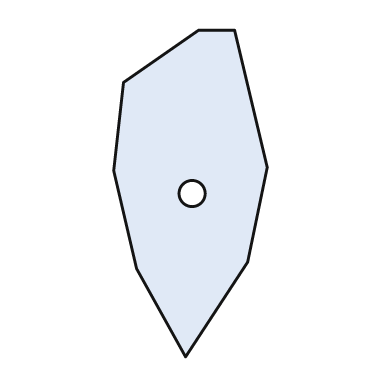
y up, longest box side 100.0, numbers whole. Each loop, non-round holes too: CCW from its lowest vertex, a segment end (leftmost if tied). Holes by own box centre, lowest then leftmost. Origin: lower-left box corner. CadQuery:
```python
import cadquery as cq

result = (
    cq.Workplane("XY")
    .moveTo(22.0, 0.0)
    .lineTo(41.0, 29.0)
    .lineTo(47.0, 58.0)
    .lineTo(37.0, 100.0)
    .lineTo(26.0, 100.0)
    .lineTo(3.0, 84.0)
    .lineTo(0.0, 57.0)
    .lineTo(7.0, 27.0)
    .close()
    .moveTo(24.0, 50.0)
    .circle(4.0)
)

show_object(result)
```